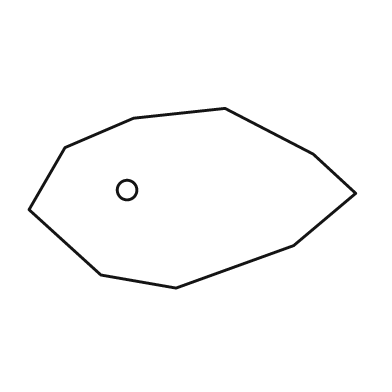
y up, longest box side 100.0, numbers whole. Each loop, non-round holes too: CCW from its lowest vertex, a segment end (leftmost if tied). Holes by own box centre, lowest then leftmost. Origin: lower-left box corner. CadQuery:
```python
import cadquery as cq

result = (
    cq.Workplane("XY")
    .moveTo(45.0, 0.0)
    .lineTo(81.0, 13.0)
    .lineTo(100.0, 29.0)
    .lineTo(87.0, 41.0)
    .lineTo(60.0, 55.0)
    .lineTo(32.0, 52.0)
    .lineTo(11.0, 43.0)
    .lineTo(0.0, 24.0)
    .lineTo(22.0, 4.0)
    .close()
    .moveTo(30.0, 30.0)
    .circle(3.0)
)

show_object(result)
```